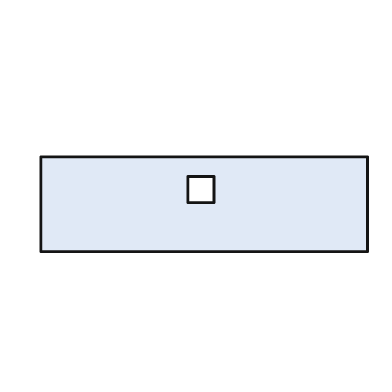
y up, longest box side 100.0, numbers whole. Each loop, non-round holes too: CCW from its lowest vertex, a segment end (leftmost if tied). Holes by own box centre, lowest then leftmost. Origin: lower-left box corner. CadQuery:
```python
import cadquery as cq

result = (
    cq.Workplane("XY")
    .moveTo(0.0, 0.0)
    .lineTo(100.0, 0.0)
    .lineTo(100.0, 29.0)
    .lineTo(0.0, 29.0)
    .close()
    .moveTo(45.0, 15.0)
    .lineTo(53.0, 15.0)
    .lineTo(53.0, 23.0)
    .lineTo(45.0, 23.0)
    .close()
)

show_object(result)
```